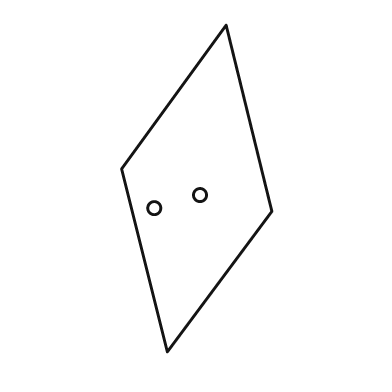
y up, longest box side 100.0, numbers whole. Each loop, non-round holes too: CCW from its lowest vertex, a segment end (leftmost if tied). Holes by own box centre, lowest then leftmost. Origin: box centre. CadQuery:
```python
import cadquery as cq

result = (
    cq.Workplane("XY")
    .moveTo(-9.0, -50.0)
    .lineTo(23.0, -7.0)
    .lineTo(9.0, 50.0)
    .lineTo(-23.0, 6.0)
    .close()
    .moveTo(-13.0, -6.0)
    .circle(2.0)
    .moveTo(1.0, -2.0)
    .circle(2.0)
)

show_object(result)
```